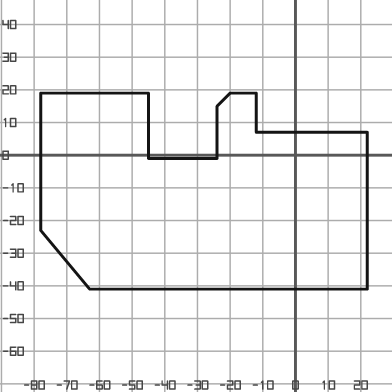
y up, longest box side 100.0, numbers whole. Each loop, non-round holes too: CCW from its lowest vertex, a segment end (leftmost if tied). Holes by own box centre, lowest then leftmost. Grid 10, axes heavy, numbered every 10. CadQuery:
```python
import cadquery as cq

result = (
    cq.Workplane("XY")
    .moveTo(-63.0, -41.0)
    .lineTo(22.0, -41.0)
    .lineTo(22.0, 7.0)
    .lineTo(-12.0, 7.0)
    .lineTo(-12.0, 19.0)
    .lineTo(-20.0, 19.0)
    .lineTo(-24.0, 15.0)
    .lineTo(-24.0, -1.0)
    .lineTo(-45.0, -1.0)
    .lineTo(-45.0, 19.0)
    .lineTo(-78.0, 19.0)
    .lineTo(-78.0, -23.0)
    .close()
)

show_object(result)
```